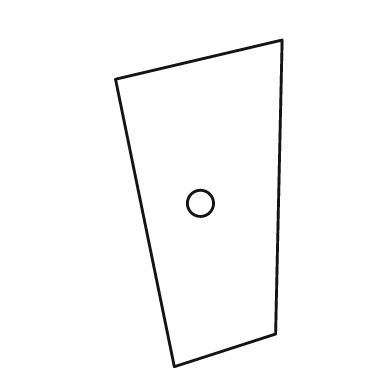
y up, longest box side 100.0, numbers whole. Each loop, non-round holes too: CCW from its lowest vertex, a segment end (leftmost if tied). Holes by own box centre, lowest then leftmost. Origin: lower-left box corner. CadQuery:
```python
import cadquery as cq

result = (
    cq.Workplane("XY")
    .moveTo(18.0, 0.0)
    .lineTo(49.0, 10.0)
    .lineTo(51.0, 100.0)
    .lineTo(0.0, 88.0)
    .close()
    .moveTo(26.0, 50.0)
    .circle(4.0)
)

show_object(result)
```